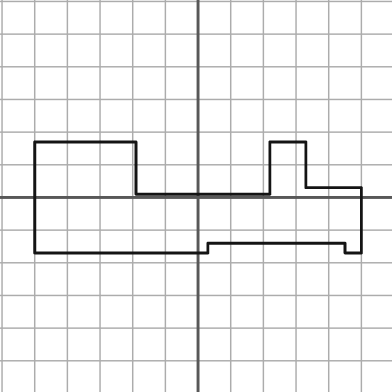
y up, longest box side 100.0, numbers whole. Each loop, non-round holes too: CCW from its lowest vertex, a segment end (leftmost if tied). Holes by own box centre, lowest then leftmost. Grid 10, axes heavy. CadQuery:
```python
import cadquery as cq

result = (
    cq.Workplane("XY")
    .moveTo(-50.0, -17.0)
    .lineTo(3.0, -17.0)
    .lineTo(3.0, -14.0)
    .lineTo(45.0, -14.0)
    .lineTo(45.0, -17.0)
    .lineTo(50.0, -17.0)
    .lineTo(50.0, 3.0)
    .lineTo(33.0, 3.0)
    .lineTo(33.0, 17.0)
    .lineTo(22.0, 17.0)
    .lineTo(22.0, 1.0)
    .lineTo(-19.0, 1.0)
    .lineTo(-19.0, 17.0)
    .lineTo(-50.0, 17.0)
    .close()
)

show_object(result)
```